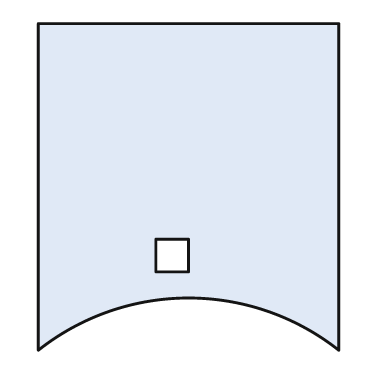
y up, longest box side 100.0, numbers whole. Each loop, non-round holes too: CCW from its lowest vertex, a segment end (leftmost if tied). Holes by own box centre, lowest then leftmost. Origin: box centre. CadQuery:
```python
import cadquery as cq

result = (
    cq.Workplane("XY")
    .moveTo(-46.0, -50.0)
    .threePointArc((0.0, -34.0), (46.0, -50.0))
    .lineTo(46.0, 50.0)
    .lineTo(-46.0, 50.0)
    .close()
    .moveTo(-10.0, -26.0)
    .lineTo(0.0, -26.0)
    .lineTo(0.0, -16.0)
    .lineTo(-10.0, -16.0)
    .close()
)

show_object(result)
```